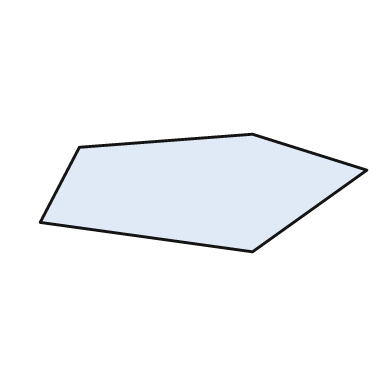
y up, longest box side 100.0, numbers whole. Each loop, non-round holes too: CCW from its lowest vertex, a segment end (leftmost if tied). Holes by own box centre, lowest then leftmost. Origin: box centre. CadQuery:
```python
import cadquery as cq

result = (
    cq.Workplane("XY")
    .moveTo(15.0, -18.0)
    .lineTo(50.0, 7.0)
    .lineTo(15.0, 18.0)
    .lineTo(-38.0, 14.0)
    .lineTo(-50.0, -9.0)
    .close()
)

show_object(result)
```